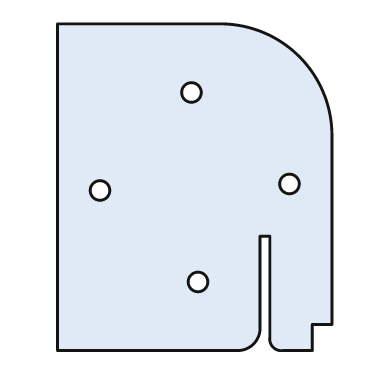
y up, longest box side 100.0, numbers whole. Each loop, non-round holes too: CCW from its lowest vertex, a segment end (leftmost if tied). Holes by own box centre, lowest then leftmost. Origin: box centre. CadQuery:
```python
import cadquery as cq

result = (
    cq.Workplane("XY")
    .moveTo(-42.0, -50.0)
    .lineTo(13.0, -50.0)
    .threePointArc((18.0, -48.0), (20.0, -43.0))
    .lineTo(20.0, -15.0)
    .lineTo(23.0, -15.0)
    .lineTo(23.0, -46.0)
    .threePointArc((24.0, -49.0), (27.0, -50.0))
    .lineTo(36.0, -50.0)
    .lineTo(36.0, -42.0)
    .lineTo(42.0, -42.0)
    .lineTo(42.0, 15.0)
    .threePointArc((32.0, 40.0), (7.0, 50.0))
    .lineTo(-42.0, 50.0)
    .close()
    .moveTo(1.0, -29.0)
    .circle(3.0)
    .moveTo(-29.0, -1.0)
    .circle(3.0)
    .moveTo(29.0, 1.0)
    .circle(3.0)
    .moveTo(-1.0, 29.0)
    .circle(3.0)
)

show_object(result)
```